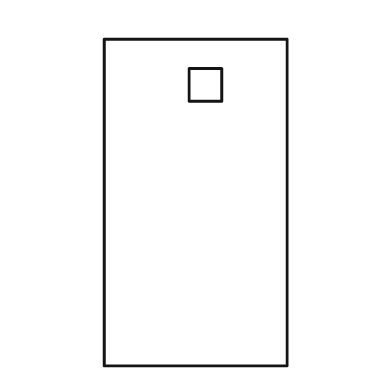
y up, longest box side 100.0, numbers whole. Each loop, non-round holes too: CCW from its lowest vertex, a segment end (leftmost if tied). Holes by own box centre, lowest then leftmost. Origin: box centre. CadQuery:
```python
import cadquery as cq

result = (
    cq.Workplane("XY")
    .moveTo(-28.0, -50.0)
    .lineTo(28.0, -50.0)
    .lineTo(28.0, 50.0)
    .lineTo(-28.0, 50.0)
    .close()
    .moveTo(-2.0, 31.0)
    .lineTo(8.0, 31.0)
    .lineTo(8.0, 41.0)
    .lineTo(-2.0, 41.0)
    .close()
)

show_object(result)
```